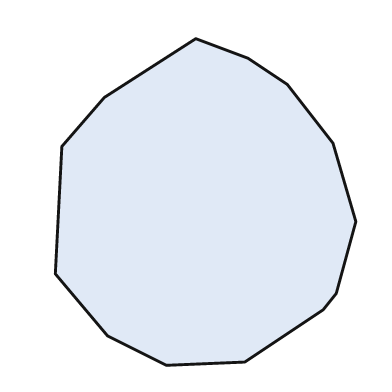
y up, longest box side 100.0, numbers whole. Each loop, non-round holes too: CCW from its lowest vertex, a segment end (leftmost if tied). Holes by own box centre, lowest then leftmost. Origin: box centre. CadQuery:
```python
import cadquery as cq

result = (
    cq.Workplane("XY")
    .moveTo(-12.0, -50.0)
    .lineTo(12.0, -49.0)
    .lineTo(36.0, -33.0)
    .lineTo(40.0, -28.0)
    .lineTo(46.0, -6.0)
    .lineTo(39.0, 18.0)
    .lineTo(25.0, 36.0)
    .lineTo(13.0, 44.0)
    .lineTo(-3.0, 50.0)
    .lineTo(-31.0, 32.0)
    .lineTo(-44.0, 17.0)
    .lineTo(-46.0, -22.0)
    .lineTo(-30.0, -41.0)
    .close()
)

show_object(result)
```